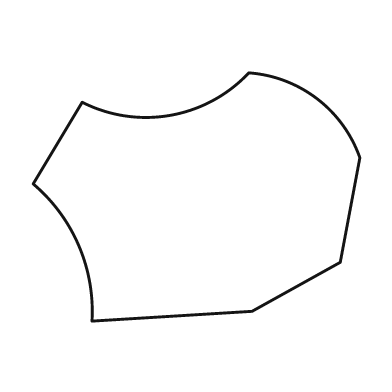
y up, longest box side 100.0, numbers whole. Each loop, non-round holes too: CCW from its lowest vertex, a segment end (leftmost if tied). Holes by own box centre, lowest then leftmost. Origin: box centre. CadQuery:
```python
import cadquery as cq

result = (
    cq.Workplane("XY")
    .moveTo(-32.0, -38.0)
    .lineTo(17.0, -35.0)
    .lineTo(44.0, -20.0)
    .lineTo(50.0, 12.0)
    .threePointArc((37.0, 30.0), (16.0, 38.0))
    .threePointArc((-8.0, 25.0), (-35.0, 29.0))
    .lineTo(-50.0, 4.0)
    .threePointArc((-36.0, -15.0), (-32.0, -38.0))
    .close()
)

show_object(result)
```